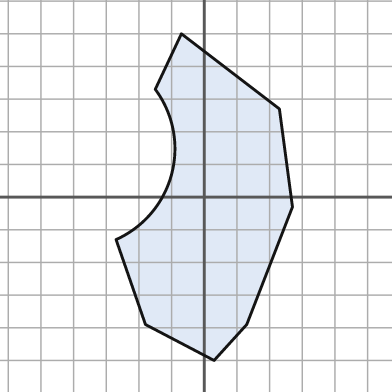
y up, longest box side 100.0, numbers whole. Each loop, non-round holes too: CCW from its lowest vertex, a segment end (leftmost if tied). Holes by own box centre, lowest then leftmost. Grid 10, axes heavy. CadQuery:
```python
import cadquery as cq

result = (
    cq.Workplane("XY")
    .moveTo(3.0, -50.0)
    .lineTo(13.0, -39.0)
    .lineTo(27.0, -3.0)
    .lineTo(23.0, 27.0)
    .lineTo(-7.0, 50.0)
    .lineTo(-15.0, 33.0)
    .threePointArc((-10.0, 7.0), (-27.0, -13.0))
    .lineTo(-18.0, -39.0)
    .close()
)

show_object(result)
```